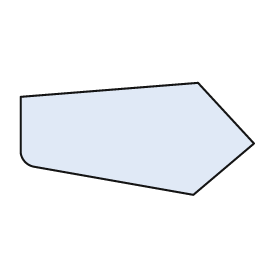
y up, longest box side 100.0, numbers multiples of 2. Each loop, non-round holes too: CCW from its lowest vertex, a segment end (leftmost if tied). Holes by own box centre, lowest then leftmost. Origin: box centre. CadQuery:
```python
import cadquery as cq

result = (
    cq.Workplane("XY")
    .moveTo(24.0, -24.0)
    .lineTo(50.0, -2.0)
    .lineTo(26.0, 24.0)
    .lineTo(-50.0, 18.0)
    .lineTo(-50.0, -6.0)
    .threePointArc((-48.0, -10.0), (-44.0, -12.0))
    .close()
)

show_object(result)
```